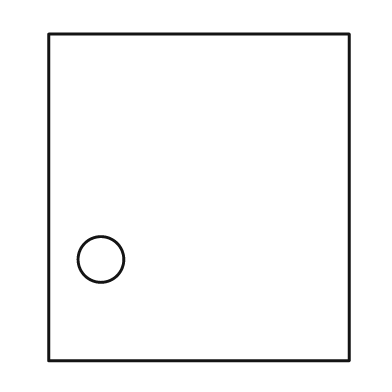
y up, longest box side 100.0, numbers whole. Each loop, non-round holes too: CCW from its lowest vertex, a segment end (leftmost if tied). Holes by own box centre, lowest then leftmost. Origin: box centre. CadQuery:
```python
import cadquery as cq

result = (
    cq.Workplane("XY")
    .moveTo(-46.0, -50.0)
    .lineTo(46.0, -50.0)
    .lineTo(46.0, 50.0)
    .lineTo(-46.0, 50.0)
    .close()
    .moveTo(-30.0, -19.0)
    .circle(7.0)
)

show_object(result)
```